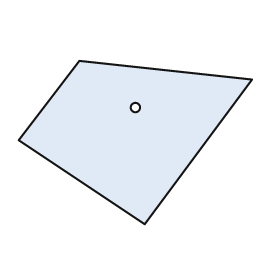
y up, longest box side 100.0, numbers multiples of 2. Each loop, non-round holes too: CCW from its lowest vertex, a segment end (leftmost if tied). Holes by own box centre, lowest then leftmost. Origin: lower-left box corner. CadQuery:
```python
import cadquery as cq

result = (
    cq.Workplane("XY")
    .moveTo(54.0, 0.0)
    .lineTo(100.0, 62.0)
    .lineTo(26.0, 70.0)
    .lineTo(0.0, 36.0)
    .close()
    .moveTo(50.0, 50.0)
    .circle(2.0)
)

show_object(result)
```